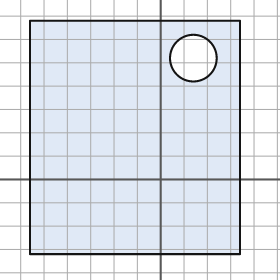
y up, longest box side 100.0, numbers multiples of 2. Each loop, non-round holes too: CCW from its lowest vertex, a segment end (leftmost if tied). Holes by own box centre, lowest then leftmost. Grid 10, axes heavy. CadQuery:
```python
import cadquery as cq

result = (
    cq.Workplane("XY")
    .moveTo(-56.0, -32.0)
    .lineTo(34.0, -32.0)
    .lineTo(34.0, 68.0)
    .lineTo(-56.0, 68.0)
    .close()
    .moveTo(14.0, 52.0)
    .circle(10.0)
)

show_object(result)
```